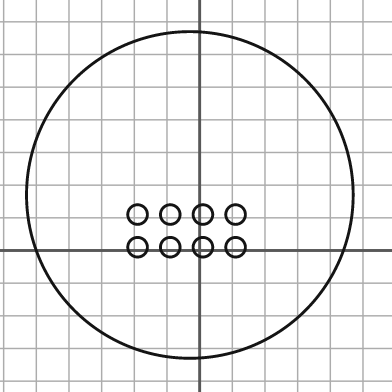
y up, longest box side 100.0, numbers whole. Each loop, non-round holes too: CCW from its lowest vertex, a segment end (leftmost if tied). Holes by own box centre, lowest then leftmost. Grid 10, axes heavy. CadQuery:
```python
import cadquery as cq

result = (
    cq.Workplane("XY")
    .moveTo(-3.0, 17.0)
    .circle(50.0)
    .moveTo(-19.0, 1.0)
    .circle(3.0)
    .moveTo(-9.0, 1.0)
    .circle(3.0)
    .moveTo(1.0, 1.0)
    .circle(3.0)
    .moveTo(11.0, 1.0)
    .circle(3.0)
    .moveTo(-19.0, 11.0)
    .circle(3.0)
    .moveTo(-9.0, 11.0)
    .circle(3.0)
    .moveTo(1.0, 11.0)
    .circle(3.0)
    .moveTo(11.0, 11.0)
    .circle(3.0)
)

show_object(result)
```